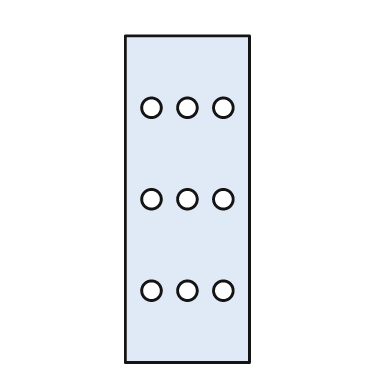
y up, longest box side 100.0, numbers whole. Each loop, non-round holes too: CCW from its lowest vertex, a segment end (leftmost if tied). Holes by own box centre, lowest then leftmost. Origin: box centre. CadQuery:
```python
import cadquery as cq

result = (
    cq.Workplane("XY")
    .moveTo(-19.0, -50.0)
    .lineTo(19.0, -50.0)
    .lineTo(19.0, 50.0)
    .lineTo(-19.0, 50.0)
    .close()
    .moveTo(-11.0, -28.0)
    .circle(3.0)
    .moveTo(0.0, -28.0)
    .circle(3.0)
    .moveTo(11.0, -28.0)
    .circle(3.0)
    .moveTo(-11.0, 0.0)
    .circle(3.0)
    .moveTo(0.0, 0.0)
    .circle(3.0)
    .moveTo(11.0, 0.0)
    .circle(3.0)
    .moveTo(-11.0, 28.0)
    .circle(3.0)
    .moveTo(0.0, 28.0)
    .circle(3.0)
    .moveTo(11.0, 28.0)
    .circle(3.0)
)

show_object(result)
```